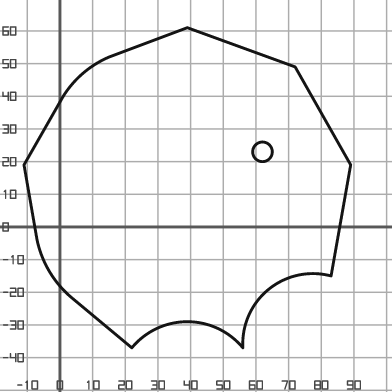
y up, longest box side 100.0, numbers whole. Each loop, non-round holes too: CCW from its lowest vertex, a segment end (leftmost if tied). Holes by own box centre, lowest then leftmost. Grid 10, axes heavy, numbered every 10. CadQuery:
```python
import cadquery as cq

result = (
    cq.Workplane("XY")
    .moveTo(22.0, -37.0)
    .threePointArc((39.0, -29.0), (56.0, -37.0))
    .threePointArc((64.0, -19.0), (83.0, -15.0))
    .lineTo(89.0, 19.0)
    .lineTo(72.0, 49.0)
    .lineTo(39.0, 61.0)
    .lineTo(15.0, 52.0)
    .threePointArc((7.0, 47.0), (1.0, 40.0))
    .lineTo(-11.0, 19.0)
    .lineTo(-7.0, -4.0)
    .threePointArc((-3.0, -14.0), (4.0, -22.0))
    .close()
    .moveTo(62.0, 23.0)
    .circle(3.0)
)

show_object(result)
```